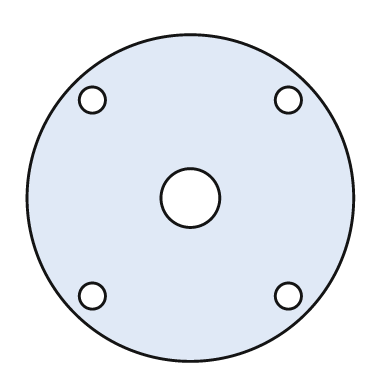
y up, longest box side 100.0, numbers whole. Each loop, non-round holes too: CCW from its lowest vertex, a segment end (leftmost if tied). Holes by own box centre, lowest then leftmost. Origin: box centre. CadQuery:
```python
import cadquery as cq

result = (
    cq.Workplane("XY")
    .moveTo(0.0, 0.0)
    .circle(50.0)
    .moveTo(-30.0, -30.0)
    .circle(4.0)
    .moveTo(30.0, -30.0)
    .circle(4.0)
    .moveTo(0.0, 0.0)
    .circle(9.0)
    .moveTo(-30.0, 30.0)
    .circle(4.0)
    .moveTo(30.0, 30.0)
    .circle(4.0)
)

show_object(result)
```